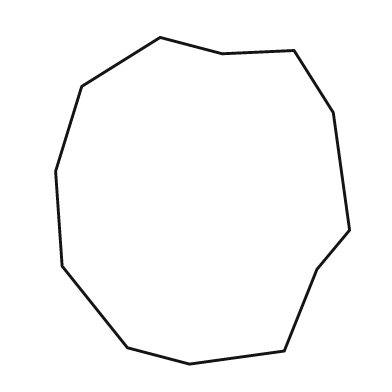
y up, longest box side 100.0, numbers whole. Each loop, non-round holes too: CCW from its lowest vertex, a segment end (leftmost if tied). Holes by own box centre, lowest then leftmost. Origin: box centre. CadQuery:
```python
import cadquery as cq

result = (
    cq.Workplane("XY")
    .moveTo(-4.0, -50.0)
    .lineTo(25.0, -46.0)
    .lineTo(35.0, -21.0)
    .lineTo(45.0, -9.0)
    .lineTo(40.0, 27.0)
    .lineTo(28.0, 46.0)
    .lineTo(6.0, 45.0)
    .lineTo(-13.0, 50.0)
    .lineTo(-37.0, 35.0)
    .lineTo(-45.0, 9.0)
    .lineTo(-43.0, -20.0)
    .lineTo(-23.0, -45.0)
    .close()
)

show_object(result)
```